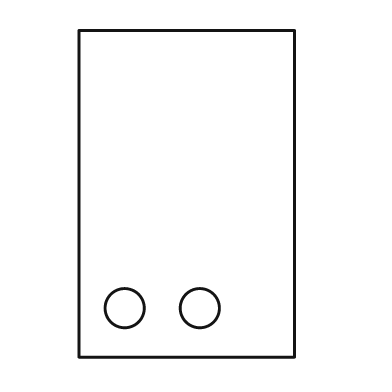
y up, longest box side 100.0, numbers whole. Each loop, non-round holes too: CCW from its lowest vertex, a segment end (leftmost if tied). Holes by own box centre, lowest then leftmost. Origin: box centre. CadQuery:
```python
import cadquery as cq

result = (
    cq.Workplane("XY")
    .moveTo(-33.0, -50.0)
    .lineTo(33.0, -50.0)
    .lineTo(33.0, 50.0)
    .lineTo(-33.0, 50.0)
    .close()
    .moveTo(-19.0, -35.0)
    .circle(6.0)
    .moveTo(4.0, -35.0)
    .circle(6.0)
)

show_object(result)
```